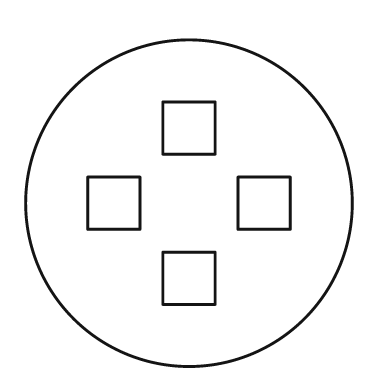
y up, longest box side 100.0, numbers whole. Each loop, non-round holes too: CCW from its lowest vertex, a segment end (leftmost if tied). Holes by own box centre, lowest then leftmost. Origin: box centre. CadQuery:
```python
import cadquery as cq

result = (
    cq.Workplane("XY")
    .moveTo(0.0, 0.0)
    .circle(50.0)
    .moveTo(-8.0, -31.0)
    .lineTo(8.0, -31.0)
    .lineTo(8.0, -15.0)
    .lineTo(-8.0, -15.0)
    .close()
    .moveTo(-31.0, -8.0)
    .lineTo(-15.0, -8.0)
    .lineTo(-15.0, 8.0)
    .lineTo(-31.0, 8.0)
    .close()
    .moveTo(15.0, -8.0)
    .lineTo(31.0, -8.0)
    .lineTo(31.0, 8.0)
    .lineTo(15.0, 8.0)
    .close()
    .moveTo(-8.0, 15.0)
    .lineTo(8.0, 15.0)
    .lineTo(8.0, 31.0)
    .lineTo(-8.0, 31.0)
    .close()
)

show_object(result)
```